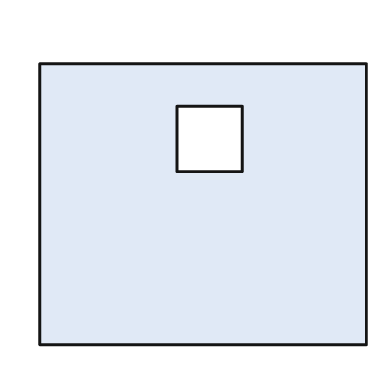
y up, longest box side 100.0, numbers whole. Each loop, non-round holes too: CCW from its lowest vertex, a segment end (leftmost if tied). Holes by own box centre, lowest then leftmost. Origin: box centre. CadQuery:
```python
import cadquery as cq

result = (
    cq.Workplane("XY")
    .moveTo(-50.0, -43.0)
    .lineTo(50.0, -43.0)
    .lineTo(50.0, 43.0)
    .lineTo(-50.0, 43.0)
    .close()
    .moveTo(-8.0, 10.0)
    .lineTo(12.0, 10.0)
    .lineTo(12.0, 30.0)
    .lineTo(-8.0, 30.0)
    .close()
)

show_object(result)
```